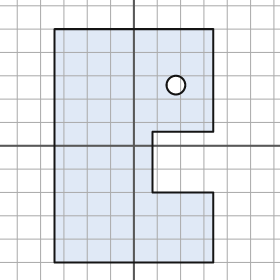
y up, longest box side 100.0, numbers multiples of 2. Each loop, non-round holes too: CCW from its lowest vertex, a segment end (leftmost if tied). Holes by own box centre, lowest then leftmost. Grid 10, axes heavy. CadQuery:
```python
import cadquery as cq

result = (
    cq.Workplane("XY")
    .moveTo(-34.0, -50.0)
    .lineTo(34.0, -50.0)
    .lineTo(34.0, -20.0)
    .lineTo(8.0, -20.0)
    .lineTo(8.0, 6.0)
    .lineTo(34.0, 6.0)
    .lineTo(34.0, 50.0)
    .lineTo(-34.0, 50.0)
    .close()
    .moveTo(18.0, 26.0)
    .circle(4.0)
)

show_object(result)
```